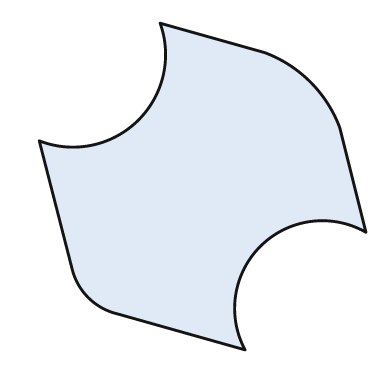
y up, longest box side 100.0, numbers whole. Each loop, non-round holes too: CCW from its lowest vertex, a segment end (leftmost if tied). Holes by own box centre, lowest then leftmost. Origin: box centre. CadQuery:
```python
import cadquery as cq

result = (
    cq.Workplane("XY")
    .moveTo(13.0, -50.0)
    .threePointArc((18.0, -18.0), (50.0, -14.0))
    .lineTo(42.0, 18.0)
    .threePointArc((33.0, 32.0), (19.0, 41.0))
    .lineTo(-13.0, 50.0)
    .threePointArc((-20.0, 20.0), (-50.0, 14.0))
    .lineTo(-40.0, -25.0)
    .threePointArc((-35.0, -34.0), (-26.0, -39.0))
    .close()
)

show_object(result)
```